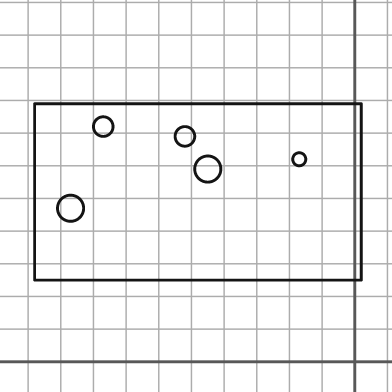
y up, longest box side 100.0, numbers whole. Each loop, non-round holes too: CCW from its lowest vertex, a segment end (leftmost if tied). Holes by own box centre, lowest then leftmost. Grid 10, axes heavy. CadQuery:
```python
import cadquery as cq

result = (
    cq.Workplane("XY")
    .moveTo(-98.0, 25.0)
    .lineTo(2.0, 25.0)
    .lineTo(2.0, 79.0)
    .lineTo(-98.0, 79.0)
    .close()
    .moveTo(-87.0, 47.0)
    .circle(4.0)
    .moveTo(-45.0, 59.0)
    .circle(4.0)
    .moveTo(-17.0, 62.0)
    .circle(2.0)
    .moveTo(-52.0, 69.0)
    .circle(3.0)
    .moveTo(-77.0, 72.0)
    .circle(3.0)
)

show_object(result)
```